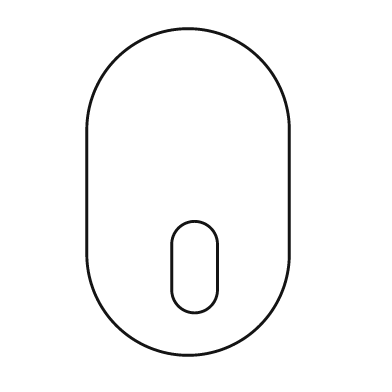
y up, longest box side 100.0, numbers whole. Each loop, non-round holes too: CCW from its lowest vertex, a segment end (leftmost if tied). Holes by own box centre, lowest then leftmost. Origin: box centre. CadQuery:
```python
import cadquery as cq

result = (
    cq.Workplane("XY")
    .moveTo(-31.0, -19.0)
    .threePointArc((0.0, -50.0), (31.0, -19.0))
    .lineTo(31.0, 19.0)
    .threePointArc((0.0, 50.0), (-31.0, 19.0))
    .close()
    .moveTo(-5.0, -30.0)
    .threePointArc((2.0, -37.0), (9.0, -30.0))
    .lineTo(9.0, -16.0)
    .threePointArc((2.0, -9.0), (-5.0, -16.0))
    .close()
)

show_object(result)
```